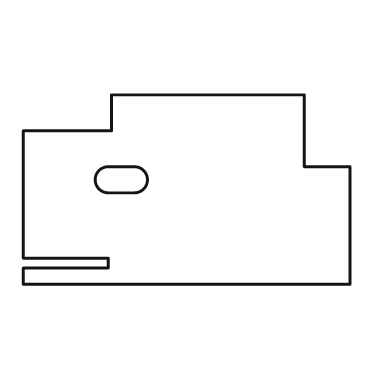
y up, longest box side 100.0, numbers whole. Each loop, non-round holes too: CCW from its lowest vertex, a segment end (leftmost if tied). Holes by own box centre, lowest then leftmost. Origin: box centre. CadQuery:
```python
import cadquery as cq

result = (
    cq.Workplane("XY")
    .moveTo(-50.0, -29.0)
    .lineTo(50.0, -29.0)
    .lineTo(50.0, 7.0)
    .lineTo(36.0, 7.0)
    .lineTo(36.0, 29.0)
    .lineTo(-23.0, 29.0)
    .lineTo(-23.0, 18.0)
    .lineTo(-50.0, 18.0)
    .lineTo(-50.0, -21.0)
    .lineTo(-24.0, -21.0)
    .lineTo(-24.0, -24.0)
    .lineTo(-50.0, -24.0)
    .close()
    .moveTo(-24.0, -1.0)
    .lineTo(-16.0, -1.0)
    .threePointArc((-12.0, 3.0), (-16.0, 7.0))
    .lineTo(-24.0, 7.0)
    .threePointArc((-28.0, 3.0), (-24.0, -1.0))
    .close()
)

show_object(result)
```